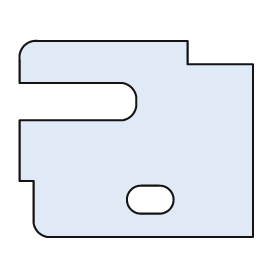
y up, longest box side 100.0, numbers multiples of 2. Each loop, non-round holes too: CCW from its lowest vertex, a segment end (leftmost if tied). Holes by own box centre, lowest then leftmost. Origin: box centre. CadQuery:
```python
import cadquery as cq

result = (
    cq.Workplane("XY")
    .moveTo(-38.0, -42.0)
    .lineTo(50.0, -42.0)
    .lineTo(50.0, 32.0)
    .lineTo(22.0, 32.0)
    .lineTo(22.0, 42.0)
    .lineTo(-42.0, 42.0)
    .threePointArc((-48.0, 40.0), (-50.0, 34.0))
    .lineTo(-50.0, 24.0)
    .lineTo(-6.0, 24.0)
    .threePointArc((-2.0, 22.0), (0.0, 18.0))
    .lineTo(0.0, 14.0)
    .threePointArc((-2.0, 10.0), (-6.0, 8.0))
    .lineTo(-50.0, 8.0)
    .lineTo(-50.0, -18.0)
    .lineTo(-44.0, -18.0)
    .lineTo(-44.0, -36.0)
    .threePointArc((-42.0, -40.0), (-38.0, -42.0))
    .close()
    .moveTo(2.0, -32.0)
    .lineTo(10.0, -32.0)
    .threePointArc((16.0, -26.0), (10.0, -20.0))
    .lineTo(2.0, -20.0)
    .threePointArc((-4.0, -26.0), (2.0, -32.0))
    .close()
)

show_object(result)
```